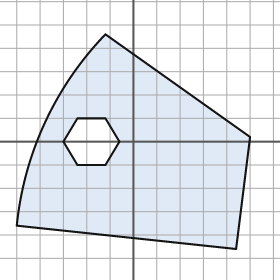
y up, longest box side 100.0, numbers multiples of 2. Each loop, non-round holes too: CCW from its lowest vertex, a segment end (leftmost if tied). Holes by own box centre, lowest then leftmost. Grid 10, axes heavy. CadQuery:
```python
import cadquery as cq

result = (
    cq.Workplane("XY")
    .moveTo(44.0, -46.0)
    .lineTo(50.0, 2.0)
    .lineTo(-12.0, 46.0)
    .threePointArc((-38.0, 8.0), (-50.0, -36.0))
    .close()
    .moveTo(-24.0, -10.0)
    .lineTo(-12.0, -10.0)
    .lineTo(-6.0, 0.0)
    .lineTo(-12.0, 10.0)
    .lineTo(-24.0, 10.0)
    .lineTo(-30.0, 0.0)
    .close()
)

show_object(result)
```